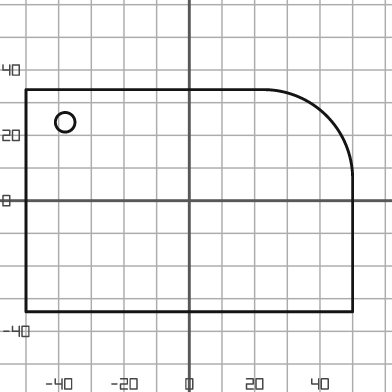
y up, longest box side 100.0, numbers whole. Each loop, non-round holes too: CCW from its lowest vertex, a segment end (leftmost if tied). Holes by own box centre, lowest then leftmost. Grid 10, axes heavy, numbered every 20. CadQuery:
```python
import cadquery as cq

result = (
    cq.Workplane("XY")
    .moveTo(-50.0, -34.0)
    .lineTo(50.0, -34.0)
    .lineTo(50.0, 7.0)
    .threePointArc((42.0, 26.0), (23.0, 34.0))
    .lineTo(-50.0, 34.0)
    .close()
    .moveTo(-38.0, 24.0)
    .circle(3.0)
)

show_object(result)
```